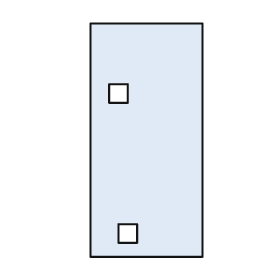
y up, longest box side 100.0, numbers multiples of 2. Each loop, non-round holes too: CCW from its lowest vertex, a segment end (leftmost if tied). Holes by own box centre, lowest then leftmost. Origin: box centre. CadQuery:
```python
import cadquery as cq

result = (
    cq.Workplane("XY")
    .moveTo(-24.0, -50.0)
    .lineTo(24.0, -50.0)
    .lineTo(24.0, 50.0)
    .lineTo(-24.0, 50.0)
    .close()
    .moveTo(-12.0, -44.0)
    .lineTo(-4.0, -44.0)
    .lineTo(-4.0, -36.0)
    .lineTo(-12.0, -36.0)
    .close()
    .moveTo(-16.0, 16.0)
    .lineTo(-8.0, 16.0)
    .lineTo(-8.0, 24.0)
    .lineTo(-16.0, 24.0)
    .close()
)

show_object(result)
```